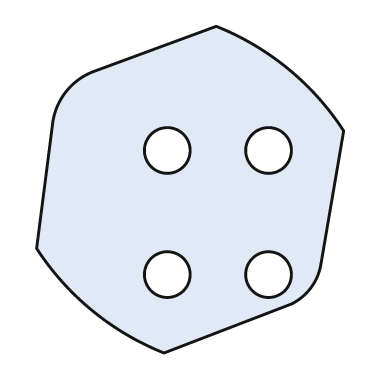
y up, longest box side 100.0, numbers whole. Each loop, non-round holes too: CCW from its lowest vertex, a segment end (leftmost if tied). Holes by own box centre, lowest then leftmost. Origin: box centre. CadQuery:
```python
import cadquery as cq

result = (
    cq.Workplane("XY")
    .moveTo(-8.0, -50.0)
    .lineTo(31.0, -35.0)
    .threePointArc((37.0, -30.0), (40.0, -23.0))
    .lineTo(47.0, 18.0)
    .threePointArc((30.0, 37.0), (8.0, 50.0))
    .lineTo(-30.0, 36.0)
    .threePointArc((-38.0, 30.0), (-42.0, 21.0))
    .lineTo(-47.0, -18.0)
    .threePointArc((-30.0, -37.0), (-8.0, -50.0))
    .close()
    .moveTo(-7.0, -26.0)
    .circle(7.0)
    .moveTo(24.0, -26.0)
    .circle(7.0)
    .moveTo(-7.0, 12.0)
    .circle(7.0)
    .moveTo(24.0, 12.0)
    .circle(7.0)
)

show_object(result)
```